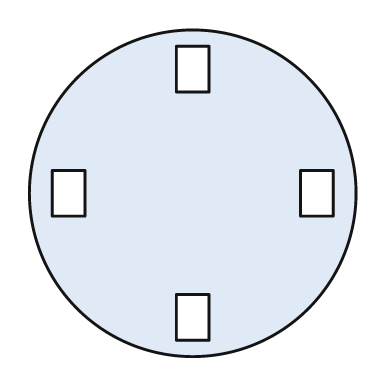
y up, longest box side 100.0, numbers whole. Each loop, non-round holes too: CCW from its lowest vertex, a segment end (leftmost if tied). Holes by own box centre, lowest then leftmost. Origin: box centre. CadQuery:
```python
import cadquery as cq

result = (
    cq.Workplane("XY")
    .moveTo(0.0, 0.0)
    .circle(50.0)
    .moveTo(-5.0, -45.0)
    .lineTo(5.0, -45.0)
    .lineTo(5.0, -31.0)
    .lineTo(-5.0, -31.0)
    .close()
    .moveTo(-43.0, -7.0)
    .lineTo(-33.0, -7.0)
    .lineTo(-33.0, 7.0)
    .lineTo(-43.0, 7.0)
    .close()
    .moveTo(33.0, -7.0)
    .lineTo(43.0, -7.0)
    .lineTo(43.0, 7.0)
    .lineTo(33.0, 7.0)
    .close()
    .moveTo(-5.0, 31.0)
    .lineTo(5.0, 31.0)
    .lineTo(5.0, 45.0)
    .lineTo(-5.0, 45.0)
    .close()
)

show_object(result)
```